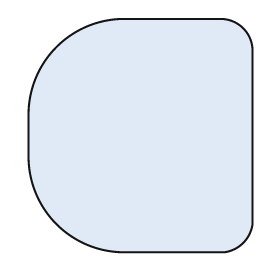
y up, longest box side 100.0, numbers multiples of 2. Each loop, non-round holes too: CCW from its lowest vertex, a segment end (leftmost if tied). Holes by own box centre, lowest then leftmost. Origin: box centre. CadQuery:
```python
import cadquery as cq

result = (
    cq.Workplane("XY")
    .moveTo(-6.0, -50.0)
    .lineTo(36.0, -50.0)
    .threePointArc((44.0, -46.0), (48.0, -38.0))
    .lineTo(48.0, 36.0)
    .threePointArc((44.0, 46.0), (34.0, 50.0))
    .lineTo(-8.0, 50.0)
    .threePointArc((-36.0, 38.0), (-48.0, 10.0))
    .lineTo(-48.0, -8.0)
    .threePointArc((-36.0, -38.0), (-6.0, -50.0))
    .close()
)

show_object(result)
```